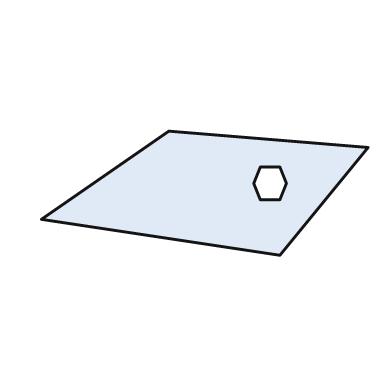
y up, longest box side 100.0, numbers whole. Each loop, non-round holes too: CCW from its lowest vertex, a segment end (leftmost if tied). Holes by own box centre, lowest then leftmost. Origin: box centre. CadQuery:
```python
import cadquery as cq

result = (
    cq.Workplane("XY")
    .moveTo(23.0, -19.0)
    .lineTo(50.0, 14.0)
    .lineTo(-11.0, 19.0)
    .lineTo(-50.0, -8.0)
    .close()
    .moveTo(17.0, -2.0)
    .lineTo(23.0, -2.0)
    .lineTo(25.0, 3.0)
    .lineTo(23.0, 8.0)
    .lineTo(17.0, 8.0)
    .lineTo(15.0, 3.0)
    .close()
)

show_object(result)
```